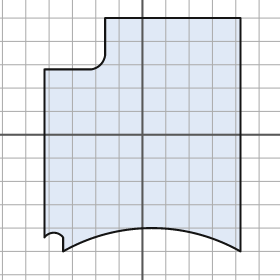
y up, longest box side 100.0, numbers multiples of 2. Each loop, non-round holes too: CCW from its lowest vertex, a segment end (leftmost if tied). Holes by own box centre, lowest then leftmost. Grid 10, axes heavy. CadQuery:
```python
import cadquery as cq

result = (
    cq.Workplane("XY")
    .moveTo(-34.0, -50.0)
    .threePointArc((4.0, -40.0), (42.0, -50.0))
    .lineTo(42.0, 50.0)
    .lineTo(-16.0, 50.0)
    .lineTo(-16.0, 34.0)
    .threePointArc((-18.0, 30.0), (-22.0, 28.0))
    .lineTo(-42.0, 28.0)
    .lineTo(-42.0, -44.0)
    .threePointArc((-38.0, -42.0), (-34.0, -44.0))
    .close()
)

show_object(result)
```